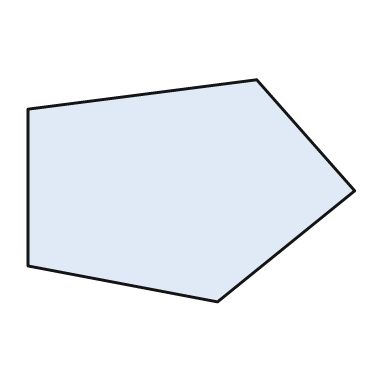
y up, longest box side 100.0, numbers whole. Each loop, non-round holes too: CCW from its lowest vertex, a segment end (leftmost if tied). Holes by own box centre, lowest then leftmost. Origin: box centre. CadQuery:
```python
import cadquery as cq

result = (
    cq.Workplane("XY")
    .moveTo(8.0, -34.0)
    .lineTo(50.0, 0.0)
    .lineTo(20.0, 34.0)
    .lineTo(-50.0, 25.0)
    .lineTo(-50.0, -23.0)
    .close()
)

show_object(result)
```